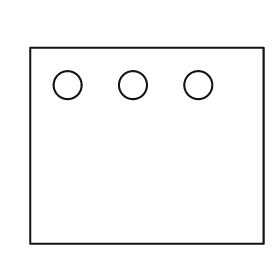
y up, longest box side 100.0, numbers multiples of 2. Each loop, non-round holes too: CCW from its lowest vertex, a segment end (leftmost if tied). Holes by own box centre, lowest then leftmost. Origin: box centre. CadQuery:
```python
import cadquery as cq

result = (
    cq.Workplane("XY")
    .moveTo(-50.0, -42.0)
    .lineTo(50.0, -42.0)
    .lineTo(50.0, 42.0)
    .lineTo(-50.0, 42.0)
    .close()
    .moveTo(-34.0, 26.0)
    .circle(6.0)
    .moveTo(-6.0, 26.0)
    .circle(6.0)
    .moveTo(22.0, 26.0)
    .circle(6.0)
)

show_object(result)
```